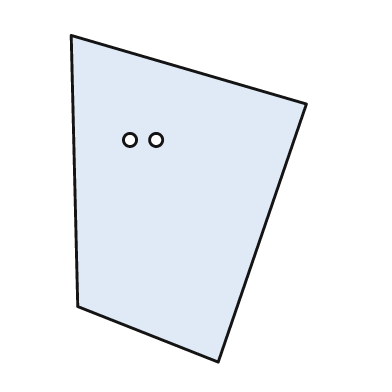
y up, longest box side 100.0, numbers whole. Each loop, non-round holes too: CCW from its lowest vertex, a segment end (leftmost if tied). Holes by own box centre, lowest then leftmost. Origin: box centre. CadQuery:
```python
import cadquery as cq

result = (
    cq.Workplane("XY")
    .moveTo(9.0, -50.0)
    .lineTo(36.0, 29.0)
    .lineTo(-36.0, 50.0)
    .lineTo(-34.0, -33.0)
    .close()
    .moveTo(-18.0, 18.0)
    .circle(2.0)
    .moveTo(-10.0, 18.0)
    .circle(2.0)
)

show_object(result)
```